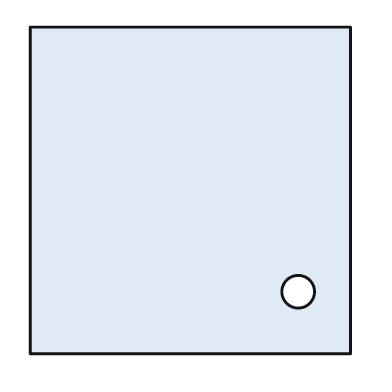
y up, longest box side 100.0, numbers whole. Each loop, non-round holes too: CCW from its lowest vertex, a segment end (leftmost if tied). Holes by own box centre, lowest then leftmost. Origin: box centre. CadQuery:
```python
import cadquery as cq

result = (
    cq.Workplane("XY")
    .moveTo(-49.0, -50.0)
    .lineTo(49.0, -50.0)
    .lineTo(49.0, 50.0)
    .lineTo(-49.0, 50.0)
    .close()
    .moveTo(33.0, -31.0)
    .circle(5.0)
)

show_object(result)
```